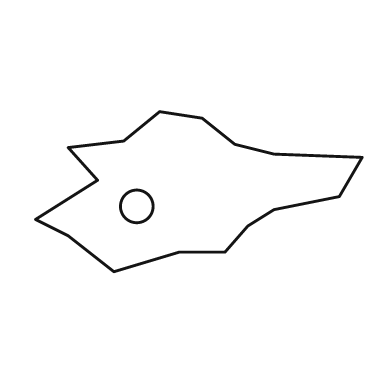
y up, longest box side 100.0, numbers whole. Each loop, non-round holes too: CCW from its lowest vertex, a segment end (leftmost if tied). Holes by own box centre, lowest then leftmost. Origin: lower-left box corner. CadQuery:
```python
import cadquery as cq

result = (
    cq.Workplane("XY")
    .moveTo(24.0, 0.0)
    .lineTo(44.0, 6.0)
    .lineTo(58.0, 6.0)
    .lineTo(65.0, 14.0)
    .lineTo(73.0, 19.0)
    .lineTo(93.0, 23.0)
    .lineTo(100.0, 35.0)
    .lineTo(73.0, 36.0)
    .lineTo(61.0, 39.0)
    .lineTo(51.0, 47.0)
    .lineTo(38.0, 49.0)
    .lineTo(27.0, 40.0)
    .lineTo(10.0, 38.0)
    .lineTo(19.0, 28.0)
    .lineTo(0.0, 16.0)
    .lineTo(10.0, 11.0)
    .close()
    .moveTo(31.0, 20.0)
    .circle(5.0)
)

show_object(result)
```